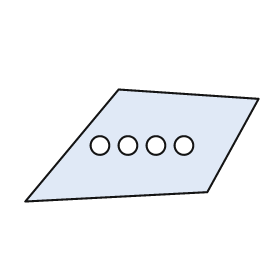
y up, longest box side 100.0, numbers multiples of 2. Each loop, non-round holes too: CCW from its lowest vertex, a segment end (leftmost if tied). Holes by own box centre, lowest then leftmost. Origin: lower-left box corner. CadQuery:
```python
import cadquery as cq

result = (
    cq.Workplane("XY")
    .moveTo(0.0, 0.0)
    .lineTo(78.0, 4.0)
    .lineTo(100.0, 44.0)
    .lineTo(40.0, 48.0)
    .close()
    .moveTo(32.0, 24.0)
    .circle(4.0)
    .moveTo(44.0, 24.0)
    .circle(4.0)
    .moveTo(56.0, 24.0)
    .circle(4.0)
    .moveTo(68.0, 24.0)
    .circle(4.0)
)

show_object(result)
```